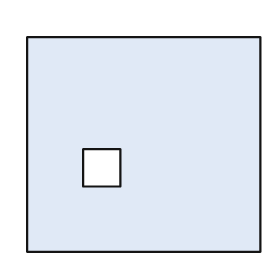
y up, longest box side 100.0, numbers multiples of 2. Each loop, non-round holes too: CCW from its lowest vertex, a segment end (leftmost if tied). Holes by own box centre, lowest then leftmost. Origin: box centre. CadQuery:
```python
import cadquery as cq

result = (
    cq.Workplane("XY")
    .moveTo(-50.0, -46.0)
    .lineTo(50.0, -46.0)
    .lineTo(50.0, 46.0)
    .lineTo(-50.0, 46.0)
    .close()
    .moveTo(-26.0, -18.0)
    .lineTo(-10.0, -18.0)
    .lineTo(-10.0, -2.0)
    .lineTo(-26.0, -2.0)
    .close()
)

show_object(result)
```